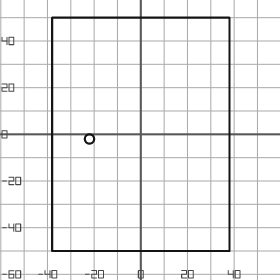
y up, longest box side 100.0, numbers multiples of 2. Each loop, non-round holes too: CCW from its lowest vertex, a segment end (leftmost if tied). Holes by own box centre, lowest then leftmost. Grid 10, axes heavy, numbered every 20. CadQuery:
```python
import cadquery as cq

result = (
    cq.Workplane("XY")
    .moveTo(-38.0, -50.0)
    .lineTo(38.0, -50.0)
    .lineTo(38.0, 50.0)
    .lineTo(-38.0, 50.0)
    .close()
    .moveTo(-22.0, -2.0)
    .circle(2.0)
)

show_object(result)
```